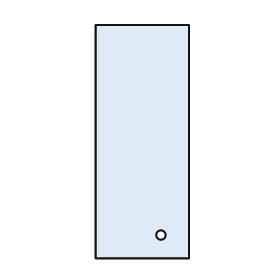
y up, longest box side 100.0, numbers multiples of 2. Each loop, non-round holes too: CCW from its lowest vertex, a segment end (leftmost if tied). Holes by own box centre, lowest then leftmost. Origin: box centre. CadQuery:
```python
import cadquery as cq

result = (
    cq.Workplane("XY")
    .moveTo(-20.0, -50.0)
    .lineTo(20.0, -50.0)
    .lineTo(20.0, 50.0)
    .lineTo(-20.0, 50.0)
    .close()
    .moveTo(8.0, -40.0)
    .circle(2.0)
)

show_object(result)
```